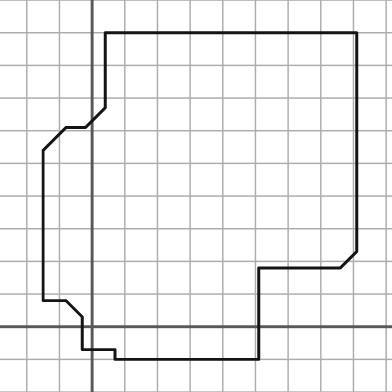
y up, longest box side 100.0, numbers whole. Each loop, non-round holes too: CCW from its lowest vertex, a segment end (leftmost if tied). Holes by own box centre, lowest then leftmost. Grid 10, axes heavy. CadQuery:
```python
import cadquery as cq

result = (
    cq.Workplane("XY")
    .moveTo(7.0, -10.0)
    .lineTo(51.0, -10.0)
    .lineTo(51.0, 18.0)
    .lineTo(76.0, 18.0)
    .lineTo(81.0, 23.0)
    .lineTo(81.0, 90.0)
    .lineTo(4.0, 90.0)
    .lineTo(4.0, 67.0)
    .lineTo(-2.0, 61.0)
    .lineTo(-8.0, 61.0)
    .lineTo(-15.0, 54.0)
    .lineTo(-15.0, 8.0)
    .lineTo(-8.0, 8.0)
    .lineTo(-3.0, 3.0)
    .lineTo(-3.0, -7.0)
    .lineTo(7.0, -7.0)
    .close()
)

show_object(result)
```